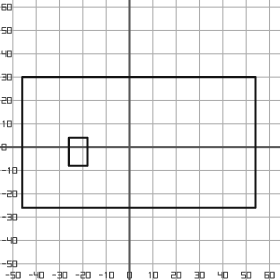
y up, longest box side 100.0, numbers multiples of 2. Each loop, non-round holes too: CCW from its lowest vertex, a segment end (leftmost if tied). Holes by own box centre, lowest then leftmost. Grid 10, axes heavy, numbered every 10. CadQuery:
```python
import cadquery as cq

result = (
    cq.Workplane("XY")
    .moveTo(-46.0, -26.0)
    .lineTo(54.0, -26.0)
    .lineTo(54.0, 30.0)
    .lineTo(-46.0, 30.0)
    .close()
    .moveTo(-26.0, -8.0)
    .lineTo(-18.0, -8.0)
    .lineTo(-18.0, 4.0)
    .lineTo(-26.0, 4.0)
    .close()
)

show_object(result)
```